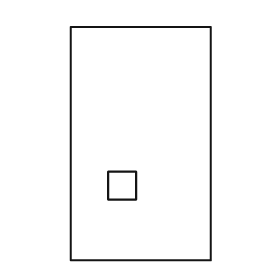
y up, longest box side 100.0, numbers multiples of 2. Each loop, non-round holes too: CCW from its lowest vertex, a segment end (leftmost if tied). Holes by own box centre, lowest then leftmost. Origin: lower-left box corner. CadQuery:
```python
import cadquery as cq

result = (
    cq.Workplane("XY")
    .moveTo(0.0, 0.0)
    .lineTo(60.0, 0.0)
    .lineTo(60.0, 100.0)
    .lineTo(0.0, 100.0)
    .close()
    .moveTo(16.0, 26.0)
    .lineTo(28.0, 26.0)
    .lineTo(28.0, 38.0)
    .lineTo(16.0, 38.0)
    .close()
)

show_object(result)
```